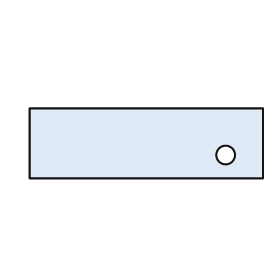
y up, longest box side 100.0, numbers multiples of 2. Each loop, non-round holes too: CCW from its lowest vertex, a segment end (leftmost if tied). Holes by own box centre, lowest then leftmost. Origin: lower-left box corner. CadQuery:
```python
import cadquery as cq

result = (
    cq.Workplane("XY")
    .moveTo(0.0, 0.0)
    .lineTo(100.0, 0.0)
    .lineTo(100.0, 30.0)
    .lineTo(0.0, 30.0)
    .close()
    .moveTo(84.0, 10.0)
    .circle(4.0)
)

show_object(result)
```